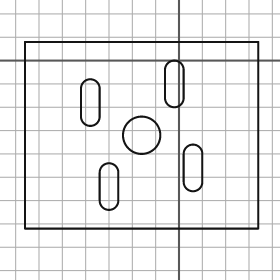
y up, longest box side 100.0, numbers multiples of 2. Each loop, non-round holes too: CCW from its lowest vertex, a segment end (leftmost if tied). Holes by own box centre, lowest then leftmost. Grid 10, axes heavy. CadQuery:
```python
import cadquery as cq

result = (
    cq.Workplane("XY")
    .moveTo(-66.0, -72.0)
    .lineTo(34.0, -72.0)
    .lineTo(34.0, 8.0)
    .lineTo(-66.0, 8.0)
    .close()
    .moveTo(-34.0, -60.0)
    .threePointArc((-30.0, -64.0), (-26.0, -60.0))
    .lineTo(-26.0, -48.0)
    .threePointArc((-30.0, -44.0), (-34.0, -48.0))
    .close()
    .moveTo(2.0, -52.0)
    .threePointArc((6.0, -56.0), (10.0, -52.0))
    .lineTo(10.0, -40.0)
    .threePointArc((6.0, -36.0), (2.0, -40.0))
    .close()
    .moveTo(-16.0, -32.0)
    .circle(8.0)
    .moveTo(-42.0, -24.0)
    .threePointArc((-38.0, -28.0), (-34.0, -24.0))
    .lineTo(-34.0, -12.0)
    .threePointArc((-38.0, -8.0), (-42.0, -12.0))
    .close()
    .moveTo(-6.0, -16.0)
    .threePointArc((-2.0, -20.0), (2.0, -16.0))
    .lineTo(2.0, -4.0)
    .threePointArc((-2.0, 0.0), (-6.0, -4.0))
    .close()
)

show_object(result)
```